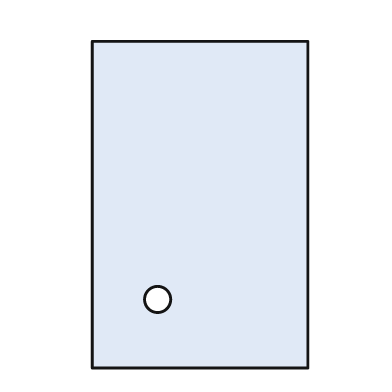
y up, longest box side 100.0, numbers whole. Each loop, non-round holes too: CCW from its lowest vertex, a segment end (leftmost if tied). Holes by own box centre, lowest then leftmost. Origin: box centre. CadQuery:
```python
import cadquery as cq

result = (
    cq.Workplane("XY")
    .moveTo(-33.0, -50.0)
    .lineTo(33.0, -50.0)
    .lineTo(33.0, 50.0)
    .lineTo(-33.0, 50.0)
    .close()
    .moveTo(-13.0, -29.0)
    .circle(4.0)
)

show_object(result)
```